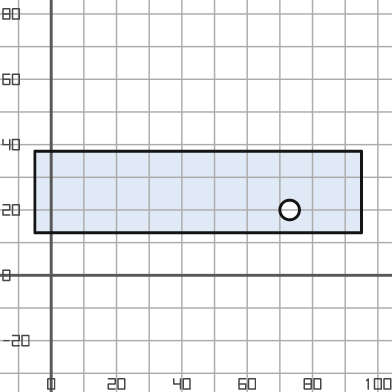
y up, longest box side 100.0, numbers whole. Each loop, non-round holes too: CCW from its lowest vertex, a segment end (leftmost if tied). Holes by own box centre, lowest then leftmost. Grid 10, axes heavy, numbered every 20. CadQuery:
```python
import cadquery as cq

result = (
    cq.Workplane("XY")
    .moveTo(-5.0, 13.0)
    .lineTo(95.0, 13.0)
    .lineTo(95.0, 38.0)
    .lineTo(-5.0, 38.0)
    .close()
    .moveTo(73.0, 20.0)
    .circle(3.0)
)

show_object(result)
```